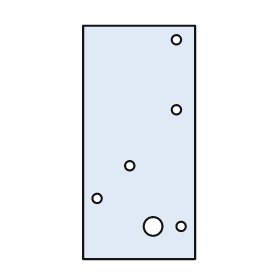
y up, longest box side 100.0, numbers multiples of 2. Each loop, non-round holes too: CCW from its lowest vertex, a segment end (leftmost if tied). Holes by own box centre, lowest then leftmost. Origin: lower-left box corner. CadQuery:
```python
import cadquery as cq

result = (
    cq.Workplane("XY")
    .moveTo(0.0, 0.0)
    .lineTo(48.0, 0.0)
    .lineTo(48.0, 100.0)
    .lineTo(0.0, 100.0)
    .close()
    .moveTo(30.0, 14.0)
    .circle(4.0)
    .moveTo(42.0, 14.0)
    .circle(2.0)
    .moveTo(6.0, 26.0)
    .circle(2.0)
    .moveTo(20.0, 40.0)
    .circle(2.0)
    .moveTo(40.0, 64.0)
    .circle(2.0)
    .moveTo(40.0, 94.0)
    .circle(2.0)
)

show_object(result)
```